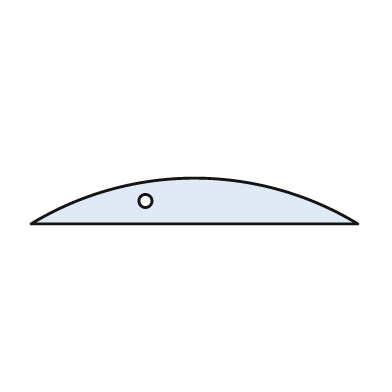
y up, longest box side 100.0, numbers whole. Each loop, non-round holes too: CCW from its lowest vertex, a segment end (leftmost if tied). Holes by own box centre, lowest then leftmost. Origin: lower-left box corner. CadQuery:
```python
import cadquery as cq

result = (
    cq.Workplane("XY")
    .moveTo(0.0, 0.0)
    .lineTo(100.0, 0.0)
    .threePointArc((50.0, 14.0), (0.0, 0.0))
    .close()
    .moveTo(35.0, 7.0)
    .circle(2.0)
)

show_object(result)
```